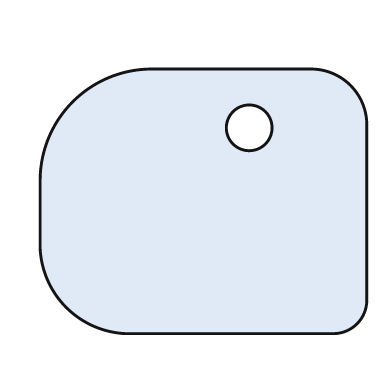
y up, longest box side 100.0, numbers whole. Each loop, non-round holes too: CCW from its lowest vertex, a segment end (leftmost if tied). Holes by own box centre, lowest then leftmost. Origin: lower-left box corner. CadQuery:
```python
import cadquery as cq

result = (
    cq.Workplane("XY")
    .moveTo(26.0, 0.0)
    .lineTo(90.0, 0.0)
    .threePointArc((97.0, 3.0), (100.0, 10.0))
    .lineTo(100.0, 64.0)
    .threePointArc((95.0, 76.0), (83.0, 81.0))
    .lineTo(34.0, 81.0)
    .threePointArc((10.0, 71.0), (0.0, 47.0))
    .lineTo(0.0, 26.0)
    .threePointArc((8.0, 8.0), (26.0, 0.0))
    .close()
    .moveTo(64.0, 63.0)
    .circle(7.0)
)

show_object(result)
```